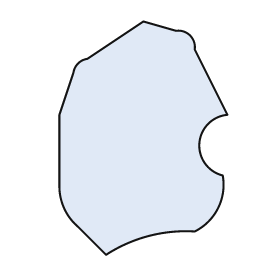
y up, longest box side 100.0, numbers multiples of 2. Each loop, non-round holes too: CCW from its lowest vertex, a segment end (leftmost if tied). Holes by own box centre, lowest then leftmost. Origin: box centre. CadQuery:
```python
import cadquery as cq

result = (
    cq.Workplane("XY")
    .moveTo(-16.0, -50.0)
    .threePointArc((2.0, -42.0), (22.0, -40.0))
    .threePointArc((32.0, -30.0), (34.0, -16.0))
    .threePointArc((24.0, -2.0), (36.0, 10.0))
    .lineTo(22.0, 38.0)
    .threePointArc((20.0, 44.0), (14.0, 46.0))
    .lineTo(0.0, 50.0)
    .lineTo(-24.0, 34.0)
    .threePointArc((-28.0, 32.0), (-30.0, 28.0))
    .lineTo(-36.0, 10.0)
    .lineTo(-36.0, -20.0)
    .threePointArc((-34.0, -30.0), (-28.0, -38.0))
    .close()
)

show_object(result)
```